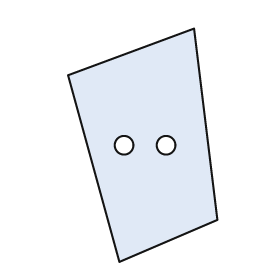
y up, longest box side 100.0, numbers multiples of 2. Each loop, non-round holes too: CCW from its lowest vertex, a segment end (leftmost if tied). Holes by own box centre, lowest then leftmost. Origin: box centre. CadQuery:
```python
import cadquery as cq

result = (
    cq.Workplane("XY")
    .moveTo(-10.0, -50.0)
    .lineTo(32.0, -32.0)
    .lineTo(22.0, 50.0)
    .lineTo(-32.0, 30.0)
    .close()
    .moveTo(-8.0, 0.0)
    .circle(4.0)
    .moveTo(10.0, 0.0)
    .circle(4.0)
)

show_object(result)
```